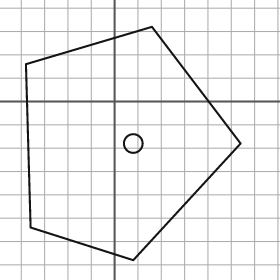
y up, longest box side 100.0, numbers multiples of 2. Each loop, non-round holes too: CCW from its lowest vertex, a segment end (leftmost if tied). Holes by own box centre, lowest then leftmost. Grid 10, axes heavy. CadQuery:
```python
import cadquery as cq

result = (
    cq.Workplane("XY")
    .moveTo(8.0, -68.0)
    .lineTo(54.0, -18.0)
    .lineTo(16.0, 32.0)
    .lineTo(-38.0, 16.0)
    .lineTo(-36.0, -54.0)
    .close()
    .moveTo(8.0, -18.0)
    .circle(4.0)
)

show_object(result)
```